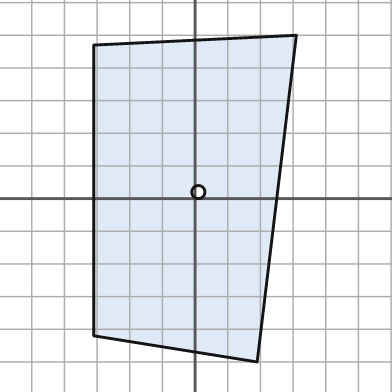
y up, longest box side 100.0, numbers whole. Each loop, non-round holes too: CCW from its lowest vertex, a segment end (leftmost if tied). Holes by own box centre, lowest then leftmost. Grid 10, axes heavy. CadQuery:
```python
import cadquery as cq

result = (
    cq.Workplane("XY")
    .moveTo(19.0, -50.0)
    .lineTo(31.0, 50.0)
    .lineTo(-31.0, 47.0)
    .lineTo(-31.0, -42.0)
    .close()
    .moveTo(1.0, 2.0)
    .circle(2.0)
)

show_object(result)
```